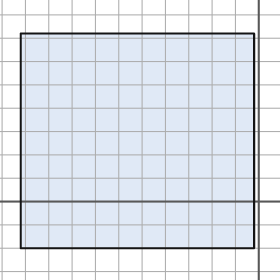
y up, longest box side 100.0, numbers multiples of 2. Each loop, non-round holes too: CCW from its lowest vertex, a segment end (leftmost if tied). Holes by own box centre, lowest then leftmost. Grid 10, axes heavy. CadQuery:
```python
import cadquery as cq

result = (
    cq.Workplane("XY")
    .moveTo(-102.0, -20.0)
    .lineTo(-2.0, -20.0)
    .lineTo(-2.0, 72.0)
    .lineTo(-102.0, 72.0)
    .close()
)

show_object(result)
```